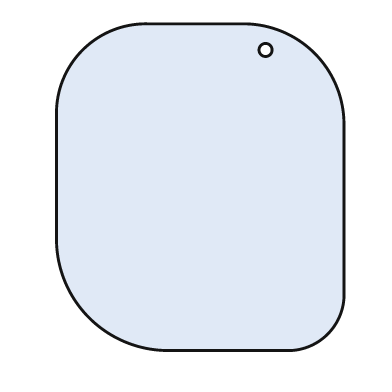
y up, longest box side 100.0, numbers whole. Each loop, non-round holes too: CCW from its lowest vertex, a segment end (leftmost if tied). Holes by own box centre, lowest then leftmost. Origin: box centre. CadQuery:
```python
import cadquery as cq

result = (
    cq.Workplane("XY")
    .moveTo(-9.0, -50.0)
    .lineTo(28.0, -50.0)
    .threePointArc((39.0, -45.0), (44.0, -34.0))
    .lineTo(44.0, 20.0)
    .threePointArc((35.0, 41.0), (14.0, 50.0))
    .lineTo(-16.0, 50.0)
    .threePointArc((-36.0, 42.0), (-44.0, 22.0))
    .lineTo(-44.0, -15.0)
    .threePointArc((-34.0, -40.0), (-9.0, -50.0))
    .close()
    .moveTo(20.0, 42.0)
    .circle(2.0)
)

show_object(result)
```